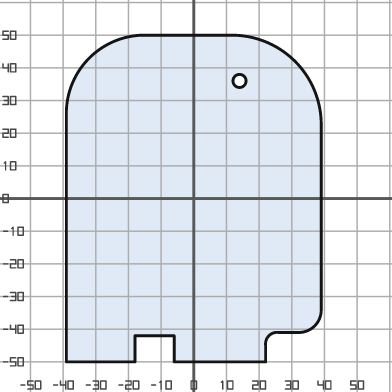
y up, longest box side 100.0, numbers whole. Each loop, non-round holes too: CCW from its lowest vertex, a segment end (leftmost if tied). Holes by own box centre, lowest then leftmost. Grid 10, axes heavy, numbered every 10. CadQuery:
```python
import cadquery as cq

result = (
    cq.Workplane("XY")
    .moveTo(-39.0, -50.0)
    .lineTo(-18.0, -50.0)
    .lineTo(-18.0, -42.0)
    .lineTo(-6.0, -42.0)
    .lineTo(-6.0, -50.0)
    .lineTo(22.0, -50.0)
    .lineTo(22.0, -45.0)
    .threePointArc((23.0, -42.0), (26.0, -41.0))
    .lineTo(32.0, -41.0)
    .threePointArc((37.0, -39.0), (39.0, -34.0))
    .lineTo(39.0, 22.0)
    .threePointArc((31.0, 42.0), (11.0, 50.0))
    .lineTo(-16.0, 50.0)
    .threePointArc((-32.0, 43.0), (-39.0, 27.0))
    .close()
    .moveTo(14.0, 36.0)
    .circle(2.0)
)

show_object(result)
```